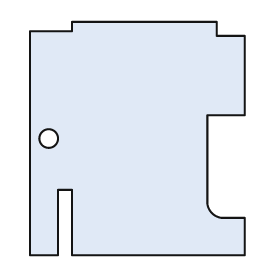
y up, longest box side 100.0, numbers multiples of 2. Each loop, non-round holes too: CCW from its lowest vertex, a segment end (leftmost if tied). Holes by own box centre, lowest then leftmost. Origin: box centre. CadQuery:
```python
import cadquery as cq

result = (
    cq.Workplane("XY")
    .moveTo(-46.0, -50.0)
    .lineTo(-34.0, -50.0)
    .lineTo(-34.0, -22.0)
    .lineTo(-28.0, -22.0)
    .lineTo(-28.0, -50.0)
    .lineTo(46.0, -50.0)
    .lineTo(46.0, -34.0)
    .lineTo(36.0, -34.0)
    .threePointArc((32.0, -32.0), (30.0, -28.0))
    .lineTo(30.0, 10.0)
    .lineTo(46.0, 10.0)
    .lineTo(46.0, 44.0)
    .lineTo(34.0, 44.0)
    .lineTo(34.0, 50.0)
    .lineTo(-28.0, 50.0)
    .lineTo(-28.0, 46.0)
    .lineTo(-46.0, 46.0)
    .close()
    .moveTo(-38.0, 0.0)
    .circle(4.0)
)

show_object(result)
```